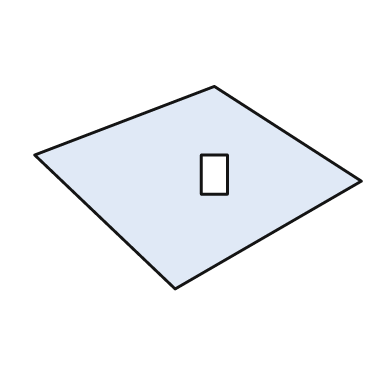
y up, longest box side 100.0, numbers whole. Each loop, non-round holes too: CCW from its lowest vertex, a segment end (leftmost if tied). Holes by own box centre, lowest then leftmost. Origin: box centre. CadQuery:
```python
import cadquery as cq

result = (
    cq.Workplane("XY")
    .moveTo(-7.0, -31.0)
    .lineTo(50.0, 2.0)
    .lineTo(5.0, 31.0)
    .lineTo(-50.0, 10.0)
    .close()
    .moveTo(1.0, -2.0)
    .lineTo(9.0, -2.0)
    .lineTo(9.0, 10.0)
    .lineTo(1.0, 10.0)
    .close()
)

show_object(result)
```